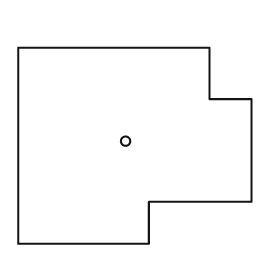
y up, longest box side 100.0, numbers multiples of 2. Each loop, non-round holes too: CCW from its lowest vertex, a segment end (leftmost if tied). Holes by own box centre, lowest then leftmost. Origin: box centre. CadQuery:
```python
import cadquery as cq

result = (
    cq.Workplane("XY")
    .moveTo(-50.0, -42.0)
    .lineTo(6.0, -42.0)
    .lineTo(6.0, -24.0)
    .lineTo(50.0, -24.0)
    .lineTo(50.0, 20.0)
    .lineTo(32.0, 20.0)
    .lineTo(32.0, 42.0)
    .lineTo(-50.0, 42.0)
    .close()
    .moveTo(-4.0, 2.0)
    .circle(2.0)
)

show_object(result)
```